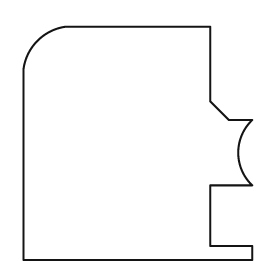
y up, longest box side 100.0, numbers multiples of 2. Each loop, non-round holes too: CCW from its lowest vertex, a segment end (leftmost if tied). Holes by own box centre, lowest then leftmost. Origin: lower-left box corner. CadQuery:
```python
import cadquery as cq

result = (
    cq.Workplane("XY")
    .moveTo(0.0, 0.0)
    .lineTo(98.0, 0.0)
    .lineTo(98.0, 6.0)
    .lineTo(80.0, 6.0)
    .lineTo(80.0, 32.0)
    .lineTo(98.0, 32.0)
    .threePointArc((92.0, 46.0), (98.0, 60.0))
    .lineTo(88.0, 60.0)
    .lineTo(80.0, 68.0)
    .lineTo(80.0, 100.0)
    .lineTo(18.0, 100.0)
    .threePointArc((6.0, 94.0), (0.0, 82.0))
    .close()
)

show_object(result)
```